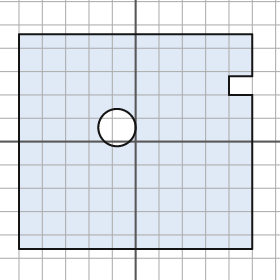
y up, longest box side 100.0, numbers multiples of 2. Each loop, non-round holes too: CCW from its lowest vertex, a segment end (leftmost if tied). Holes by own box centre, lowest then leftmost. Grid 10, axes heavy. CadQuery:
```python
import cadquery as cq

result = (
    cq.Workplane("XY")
    .moveTo(-50.0, -46.0)
    .lineTo(50.0, -46.0)
    .lineTo(50.0, 20.0)
    .lineTo(40.0, 20.0)
    .lineTo(40.0, 28.0)
    .lineTo(50.0, 28.0)
    .lineTo(50.0, 46.0)
    .lineTo(-50.0, 46.0)
    .close()
    .moveTo(-8.0, 6.0)
    .circle(8.0)
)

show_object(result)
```